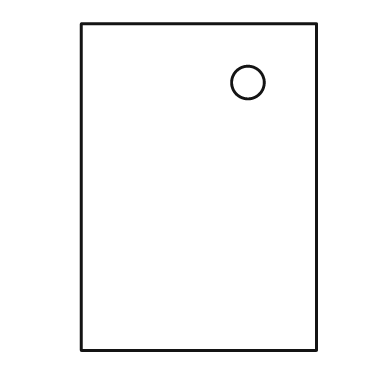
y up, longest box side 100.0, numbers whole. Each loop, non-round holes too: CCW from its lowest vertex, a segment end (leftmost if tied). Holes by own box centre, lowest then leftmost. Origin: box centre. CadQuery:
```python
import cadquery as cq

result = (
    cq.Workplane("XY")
    .moveTo(-36.0, -50.0)
    .lineTo(36.0, -50.0)
    .lineTo(36.0, 50.0)
    .lineTo(-36.0, 50.0)
    .close()
    .moveTo(15.0, 32.0)
    .circle(5.0)
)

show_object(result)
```